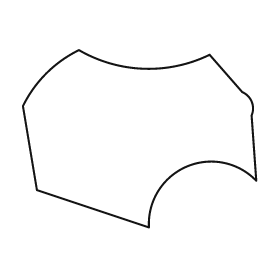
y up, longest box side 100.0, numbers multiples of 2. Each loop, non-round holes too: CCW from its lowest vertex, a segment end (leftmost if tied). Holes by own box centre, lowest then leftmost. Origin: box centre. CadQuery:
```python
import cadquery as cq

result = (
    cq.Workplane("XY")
    .moveTo(4.0, -38.0)
    .threePointArc((20.0, -12.0), (50.0, -18.0))
    .lineTo(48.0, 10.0)
    .threePointArc((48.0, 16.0), (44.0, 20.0))
    .lineTo(30.0, 36.0)
    .threePointArc((2.0, 30.0), (-26.0, 38.0))
    .threePointArc((-40.0, 28.0), (-50.0, 14.0))
    .lineTo(-44.0, -22.0)
    .close()
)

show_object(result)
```